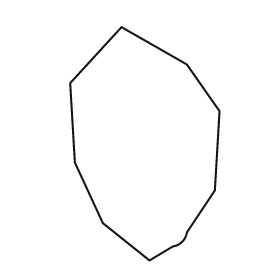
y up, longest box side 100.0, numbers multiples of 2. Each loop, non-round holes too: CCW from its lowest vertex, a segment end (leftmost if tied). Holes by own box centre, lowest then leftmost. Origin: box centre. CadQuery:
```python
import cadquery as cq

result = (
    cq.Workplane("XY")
    .moveTo(2.0, -50.0)
    .lineTo(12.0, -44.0)
    .threePointArc((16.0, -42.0), (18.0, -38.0))
    .lineTo(30.0, -20.0)
    .lineTo(32.0, 14.0)
    .lineTo(18.0, 34.0)
    .lineTo(-10.0, 50.0)
    .lineTo(-32.0, 26.0)
    .lineTo(-30.0, -8.0)
    .lineTo(-18.0, -34.0)
    .close()
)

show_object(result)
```